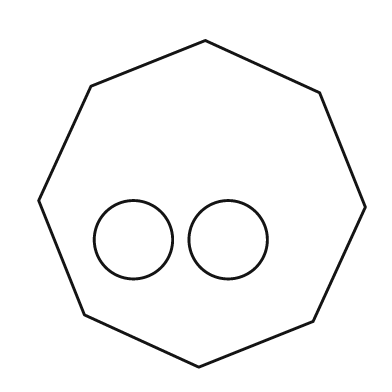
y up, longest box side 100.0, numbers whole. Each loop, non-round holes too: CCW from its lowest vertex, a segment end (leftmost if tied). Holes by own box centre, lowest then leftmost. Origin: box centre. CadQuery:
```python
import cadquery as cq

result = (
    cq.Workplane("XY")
    .moveTo(-1.0, -50.0)
    .lineTo(34.0, -36.0)
    .lineTo(50.0, -1.0)
    .lineTo(36.0, 34.0)
    .lineTo(1.0, 50.0)
    .lineTo(-34.0, 36.0)
    .lineTo(-50.0, 1.0)
    .lineTo(-36.0, -34.0)
    .close()
    .moveTo(-21.0, -11.0)
    .circle(12.0)
    .moveTo(8.0, -11.0)
    .circle(12.0)
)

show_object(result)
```